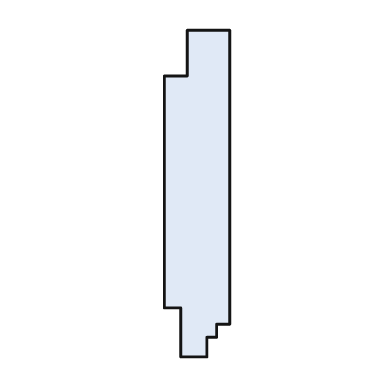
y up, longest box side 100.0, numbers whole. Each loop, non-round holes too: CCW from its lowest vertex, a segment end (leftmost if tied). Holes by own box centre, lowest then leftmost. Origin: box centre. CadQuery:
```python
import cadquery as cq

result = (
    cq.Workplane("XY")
    .moveTo(-5.0, -50.0)
    .lineTo(3.0, -50.0)
    .lineTo(3.0, -44.0)
    .lineTo(6.0, -44.0)
    .lineTo(6.0, -40.0)
    .lineTo(10.0, -40.0)
    .lineTo(10.0, 50.0)
    .lineTo(-3.0, 50.0)
    .lineTo(-3.0, 36.0)
    .lineTo(-10.0, 36.0)
    .lineTo(-10.0, -35.0)
    .lineTo(-5.0, -35.0)
    .close()
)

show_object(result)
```